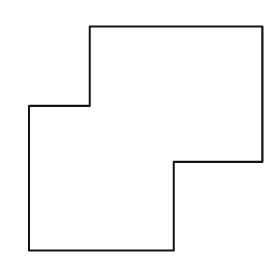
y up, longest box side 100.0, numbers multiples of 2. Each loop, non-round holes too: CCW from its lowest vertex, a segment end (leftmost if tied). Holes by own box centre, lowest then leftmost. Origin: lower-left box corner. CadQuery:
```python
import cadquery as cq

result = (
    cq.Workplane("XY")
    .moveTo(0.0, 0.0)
    .lineTo(62.0, 0.0)
    .lineTo(62.0, 38.0)
    .lineTo(100.0, 38.0)
    .lineTo(100.0, 96.0)
    .lineTo(26.0, 96.0)
    .lineTo(26.0, 62.0)
    .lineTo(0.0, 62.0)
    .close()
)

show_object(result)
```